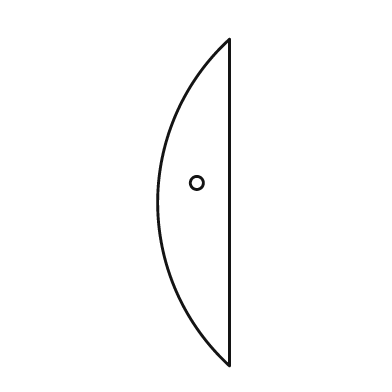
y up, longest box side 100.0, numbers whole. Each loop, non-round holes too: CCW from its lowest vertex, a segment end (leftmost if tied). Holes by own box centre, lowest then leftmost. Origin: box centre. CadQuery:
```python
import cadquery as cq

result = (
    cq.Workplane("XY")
    .moveTo(11.0, -50.0)
    .lineTo(11.0, 50.0)
    .threePointArc((-11.0, 0.0), (11.0, -50.0))
    .close()
    .moveTo(1.0, 6.0)
    .circle(2.0)
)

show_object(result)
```